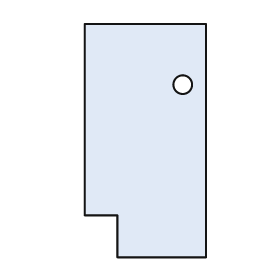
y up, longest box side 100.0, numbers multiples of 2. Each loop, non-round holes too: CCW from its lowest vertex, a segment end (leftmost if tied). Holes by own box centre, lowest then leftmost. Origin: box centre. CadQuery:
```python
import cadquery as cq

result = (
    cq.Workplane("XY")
    .moveTo(-12.0, -50.0)
    .lineTo(26.0, -50.0)
    .lineTo(26.0, 50.0)
    .lineTo(-26.0, 50.0)
    .lineTo(-26.0, -32.0)
    .lineTo(-12.0, -32.0)
    .close()
    .moveTo(16.0, 24.0)
    .circle(4.0)
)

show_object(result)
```